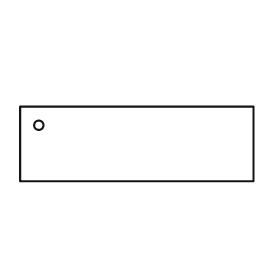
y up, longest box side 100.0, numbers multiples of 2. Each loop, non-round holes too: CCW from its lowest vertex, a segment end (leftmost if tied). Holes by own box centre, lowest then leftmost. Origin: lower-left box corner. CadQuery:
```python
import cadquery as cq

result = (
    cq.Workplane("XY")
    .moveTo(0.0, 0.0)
    .lineTo(100.0, 0.0)
    .lineTo(100.0, 32.0)
    .lineTo(0.0, 32.0)
    .close()
    .moveTo(8.0, 24.0)
    .circle(2.0)
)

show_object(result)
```